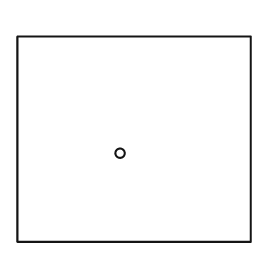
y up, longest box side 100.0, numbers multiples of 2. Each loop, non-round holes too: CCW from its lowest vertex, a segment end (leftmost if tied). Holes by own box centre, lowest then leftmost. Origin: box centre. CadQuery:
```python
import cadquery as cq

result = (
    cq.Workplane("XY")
    .moveTo(-50.0, -44.0)
    .lineTo(50.0, -44.0)
    .lineTo(50.0, 44.0)
    .lineTo(-50.0, 44.0)
    .close()
    .moveTo(-6.0, -6.0)
    .circle(2.0)
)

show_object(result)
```